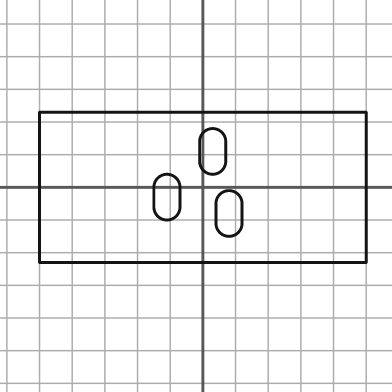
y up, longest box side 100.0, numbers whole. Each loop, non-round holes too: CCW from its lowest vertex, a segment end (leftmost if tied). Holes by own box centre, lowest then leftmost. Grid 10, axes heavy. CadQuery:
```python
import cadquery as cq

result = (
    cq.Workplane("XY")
    .moveTo(-50.0, -23.0)
    .lineTo(50.0, -23.0)
    .lineTo(50.0, 23.0)
    .lineTo(-50.0, 23.0)
    .close()
    .moveTo(4.0, -11.0)
    .threePointArc((8.0, -15.0), (12.0, -11.0))
    .lineTo(12.0, -5.0)
    .threePointArc((8.0, -1.0), (4.0, -5.0))
    .close()
    .moveTo(-15.0, -6.0)
    .threePointArc((-11.0, -10.0), (-7.0, -6.0))
    .lineTo(-7.0, 0.0)
    .threePointArc((-11.0, 4.0), (-15.0, 0.0))
    .close()
    .moveTo(-1.0, 8.0)
    .threePointArc((3.0, 4.0), (7.0, 8.0))
    .lineTo(7.0, 14.0)
    .threePointArc((3.0, 18.0), (-1.0, 14.0))
    .close()
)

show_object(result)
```